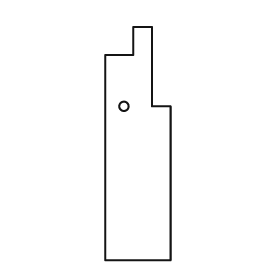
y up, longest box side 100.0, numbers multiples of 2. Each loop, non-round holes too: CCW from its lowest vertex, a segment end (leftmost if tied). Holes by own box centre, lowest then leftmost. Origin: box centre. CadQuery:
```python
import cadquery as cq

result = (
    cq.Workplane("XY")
    .moveTo(-14.0, -50.0)
    .lineTo(14.0, -50.0)
    .lineTo(14.0, 16.0)
    .lineTo(6.0, 16.0)
    .lineTo(6.0, 50.0)
    .lineTo(-2.0, 50.0)
    .lineTo(-2.0, 38.0)
    .lineTo(-14.0, 38.0)
    .close()
    .moveTo(-6.0, 16.0)
    .circle(2.0)
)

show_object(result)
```